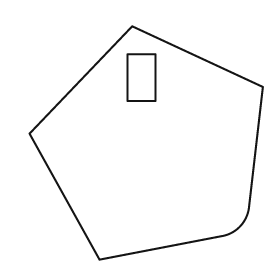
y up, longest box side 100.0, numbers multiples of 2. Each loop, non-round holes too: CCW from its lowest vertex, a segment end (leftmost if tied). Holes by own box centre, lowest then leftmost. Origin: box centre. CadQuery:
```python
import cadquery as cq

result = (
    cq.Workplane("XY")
    .moveTo(-20.0, -50.0)
    .lineTo(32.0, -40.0)
    .threePointArc((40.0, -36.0), (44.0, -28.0))
    .lineTo(50.0, 24.0)
    .lineTo(-6.0, 50.0)
    .lineTo(-50.0, 4.0)
    .close()
    .moveTo(-8.0, 18.0)
    .lineTo(4.0, 18.0)
    .lineTo(4.0, 38.0)
    .lineTo(-8.0, 38.0)
    .close()
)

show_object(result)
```